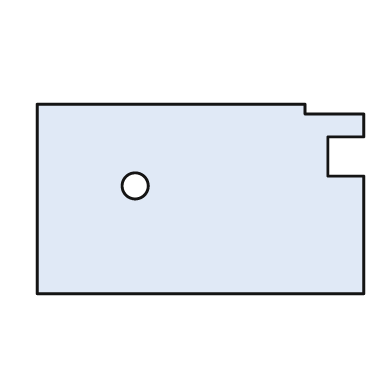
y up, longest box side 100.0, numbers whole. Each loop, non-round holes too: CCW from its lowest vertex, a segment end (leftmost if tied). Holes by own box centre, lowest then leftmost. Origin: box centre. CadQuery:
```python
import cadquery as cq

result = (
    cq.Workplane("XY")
    .moveTo(-50.0, -29.0)
    .lineTo(50.0, -29.0)
    .lineTo(50.0, 7.0)
    .lineTo(39.0, 7.0)
    .lineTo(39.0, 19.0)
    .lineTo(50.0, 19.0)
    .lineTo(50.0, 26.0)
    .lineTo(32.0, 26.0)
    .lineTo(32.0, 29.0)
    .lineTo(-50.0, 29.0)
    .close()
    .moveTo(-20.0, 4.0)
    .circle(4.0)
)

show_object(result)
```